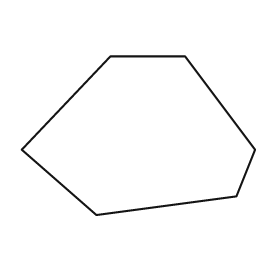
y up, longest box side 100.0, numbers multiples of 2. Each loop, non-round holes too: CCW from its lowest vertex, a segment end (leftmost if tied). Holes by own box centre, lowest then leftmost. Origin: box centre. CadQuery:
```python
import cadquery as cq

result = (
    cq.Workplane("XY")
    .moveTo(-18.0, -34.0)
    .lineTo(42.0, -26.0)
    .lineTo(50.0, -6.0)
    .lineTo(20.0, 34.0)
    .lineTo(-12.0, 34.0)
    .lineTo(-50.0, -6.0)
    .close()
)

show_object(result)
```